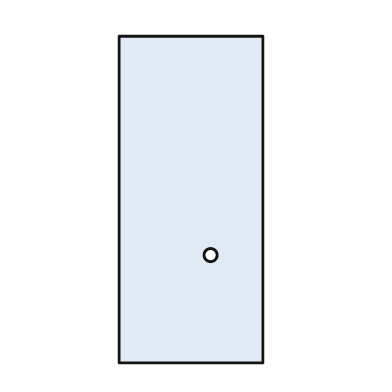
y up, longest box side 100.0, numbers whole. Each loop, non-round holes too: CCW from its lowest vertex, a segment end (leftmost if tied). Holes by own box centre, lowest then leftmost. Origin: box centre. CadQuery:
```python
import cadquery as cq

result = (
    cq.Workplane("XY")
    .moveTo(-22.0, -50.0)
    .lineTo(22.0, -50.0)
    .lineTo(22.0, 50.0)
    .lineTo(-22.0, 50.0)
    .close()
    .moveTo(6.0, -17.0)
    .circle(2.0)
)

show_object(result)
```